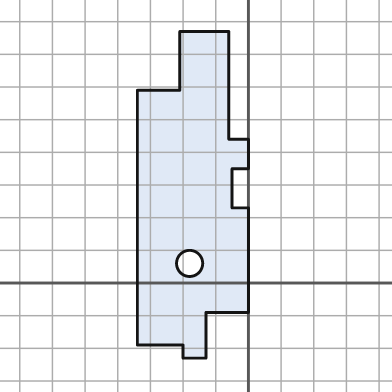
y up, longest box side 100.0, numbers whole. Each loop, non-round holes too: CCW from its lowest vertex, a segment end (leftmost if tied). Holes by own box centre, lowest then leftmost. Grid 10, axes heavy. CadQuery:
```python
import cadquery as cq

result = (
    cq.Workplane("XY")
    .moveTo(-20.0, -23.0)
    .lineTo(-13.0, -23.0)
    .lineTo(-13.0, -9.0)
    .lineTo(0.0, -9.0)
    .lineTo(0.0, 23.0)
    .lineTo(-5.0, 23.0)
    .lineTo(-5.0, 35.0)
    .lineTo(0.0, 35.0)
    .lineTo(0.0, 44.0)
    .lineTo(-6.0, 44.0)
    .lineTo(-6.0, 77.0)
    .lineTo(-21.0, 77.0)
    .lineTo(-21.0, 59.0)
    .lineTo(-34.0, 59.0)
    .lineTo(-34.0, -19.0)
    .lineTo(-20.0, -19.0)
    .close()
    .moveTo(-18.0, 6.0)
    .circle(4.0)
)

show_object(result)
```